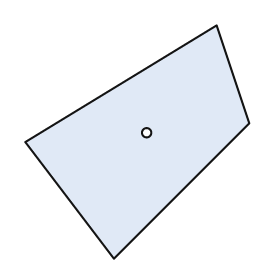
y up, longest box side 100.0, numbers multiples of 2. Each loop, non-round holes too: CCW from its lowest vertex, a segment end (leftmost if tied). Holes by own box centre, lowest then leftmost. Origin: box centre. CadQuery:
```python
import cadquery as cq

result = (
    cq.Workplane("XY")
    .moveTo(-10.0, -50.0)
    .lineTo(48.0, 8.0)
    .lineTo(34.0, 50.0)
    .lineTo(-48.0, 0.0)
    .close()
    .moveTo(4.0, 4.0)
    .circle(2.0)
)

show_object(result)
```